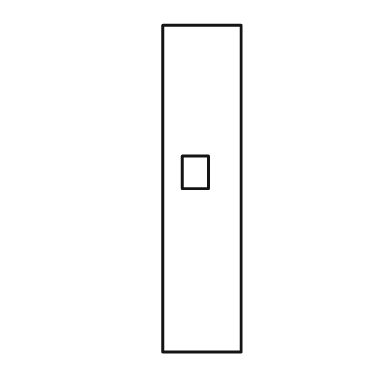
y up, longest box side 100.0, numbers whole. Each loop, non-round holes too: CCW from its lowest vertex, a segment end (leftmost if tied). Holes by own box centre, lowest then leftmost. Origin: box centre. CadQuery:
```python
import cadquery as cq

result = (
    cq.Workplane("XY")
    .moveTo(-12.0, -50.0)
    .lineTo(12.0, -50.0)
    .lineTo(12.0, 50.0)
    .lineTo(-12.0, 50.0)
    .close()
    .moveTo(-6.0, 0.0)
    .lineTo(2.0, 0.0)
    .lineTo(2.0, 10.0)
    .lineTo(-6.0, 10.0)
    .close()
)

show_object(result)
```